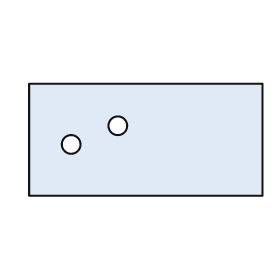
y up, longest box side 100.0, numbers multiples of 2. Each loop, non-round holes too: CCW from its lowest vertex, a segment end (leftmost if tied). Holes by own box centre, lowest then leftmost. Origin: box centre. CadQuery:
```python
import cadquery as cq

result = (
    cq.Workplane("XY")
    .moveTo(-50.0, -24.0)
    .lineTo(50.0, -24.0)
    .lineTo(50.0, 24.0)
    .lineTo(-50.0, 24.0)
    .close()
    .moveTo(-32.0, -2.0)
    .circle(4.0)
    .moveTo(-12.0, 6.0)
    .circle(4.0)
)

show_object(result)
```